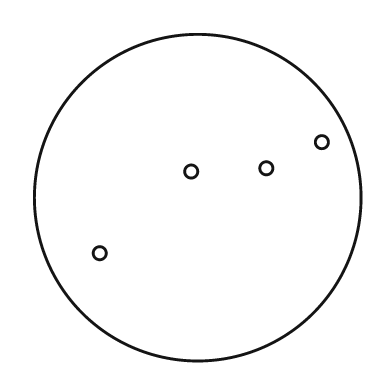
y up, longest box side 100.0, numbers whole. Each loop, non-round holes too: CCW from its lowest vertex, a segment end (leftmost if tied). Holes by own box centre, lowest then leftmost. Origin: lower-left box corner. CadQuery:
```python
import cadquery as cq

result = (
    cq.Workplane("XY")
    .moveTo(50.0, 50.0)
    .circle(50.0)
    .moveTo(20.0, 33.0)
    .circle(2.0)
    .moveTo(48.0, 58.0)
    .circle(2.0)
    .moveTo(71.0, 59.0)
    .circle(2.0)
    .moveTo(88.0, 67.0)
    .circle(2.0)
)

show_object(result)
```